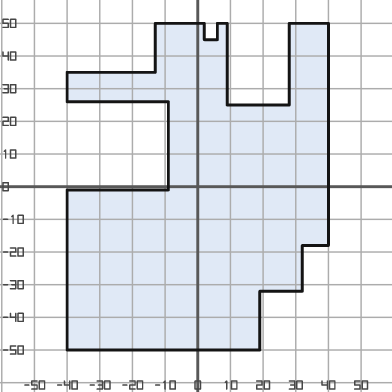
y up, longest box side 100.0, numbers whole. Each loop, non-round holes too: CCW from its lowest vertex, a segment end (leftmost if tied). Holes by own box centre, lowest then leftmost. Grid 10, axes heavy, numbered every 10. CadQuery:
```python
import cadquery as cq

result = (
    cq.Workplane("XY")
    .moveTo(-40.0, -50.0)
    .lineTo(19.0, -50.0)
    .lineTo(19.0, -32.0)
    .lineTo(32.0, -32.0)
    .lineTo(32.0, -18.0)
    .lineTo(40.0, -18.0)
    .lineTo(40.0, 50.0)
    .lineTo(28.0, 50.0)
    .lineTo(28.0, 25.0)
    .lineTo(9.0, 25.0)
    .lineTo(9.0, 50.0)
    .lineTo(6.0, 50.0)
    .lineTo(6.0, 45.0)
    .lineTo(2.0, 45.0)
    .lineTo(2.0, 50.0)
    .lineTo(-13.0, 50.0)
    .lineTo(-13.0, 35.0)
    .lineTo(-40.0, 35.0)
    .lineTo(-40.0, 26.0)
    .lineTo(-9.0, 26.0)
    .lineTo(-9.0, -1.0)
    .lineTo(-40.0, -1.0)
    .close()
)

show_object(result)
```